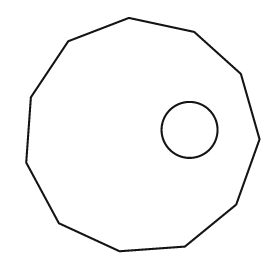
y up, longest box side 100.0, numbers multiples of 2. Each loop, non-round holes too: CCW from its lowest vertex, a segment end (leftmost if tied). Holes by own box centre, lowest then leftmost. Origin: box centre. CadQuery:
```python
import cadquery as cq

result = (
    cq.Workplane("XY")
    .moveTo(-10.0, -50.0)
    .lineTo(18.0, -48.0)
    .lineTo(40.0, -30.0)
    .lineTo(50.0, -2.0)
    .lineTo(42.0, 26.0)
    .lineTo(22.0, 44.0)
    .lineTo(-6.0, 50.0)
    .lineTo(-32.0, 40.0)
    .lineTo(-48.0, 16.0)
    .lineTo(-50.0, -12.0)
    .lineTo(-36.0, -38.0)
    .close()
    .moveTo(20.0, 2.0)
    .circle(12.0)
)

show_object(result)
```